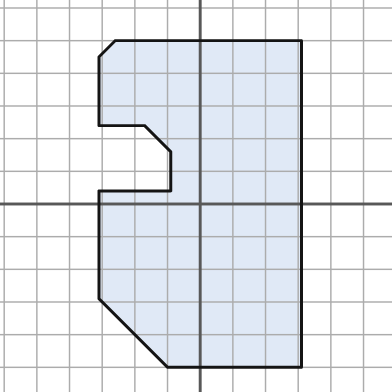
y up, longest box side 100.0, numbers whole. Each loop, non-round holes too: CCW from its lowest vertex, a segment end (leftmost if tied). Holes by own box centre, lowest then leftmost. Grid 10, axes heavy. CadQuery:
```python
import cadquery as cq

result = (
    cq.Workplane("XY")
    .moveTo(-10.0, -50.0)
    .lineTo(31.0, -50.0)
    .lineTo(31.0, 50.0)
    .lineTo(-26.0, 50.0)
    .lineTo(-31.0, 45.0)
    .lineTo(-31.0, 24.0)
    .lineTo(-17.0, 24.0)
    .lineTo(-9.0, 16.0)
    .lineTo(-9.0, 4.0)
    .lineTo(-31.0, 4.0)
    .lineTo(-31.0, -29.0)
    .close()
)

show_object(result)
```